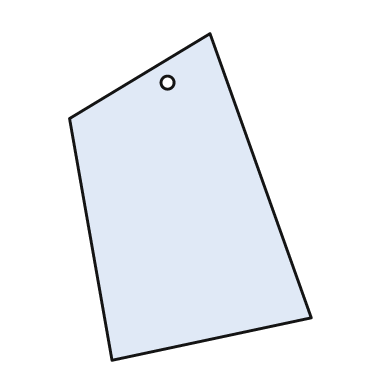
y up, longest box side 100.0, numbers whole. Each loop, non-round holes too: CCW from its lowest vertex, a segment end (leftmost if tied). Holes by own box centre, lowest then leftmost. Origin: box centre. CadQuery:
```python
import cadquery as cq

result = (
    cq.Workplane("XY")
    .moveTo(-24.0, -50.0)
    .lineTo(37.0, -37.0)
    .lineTo(6.0, 50.0)
    .lineTo(-37.0, 24.0)
    .close()
    .moveTo(-7.0, 35.0)
    .circle(2.0)
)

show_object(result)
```